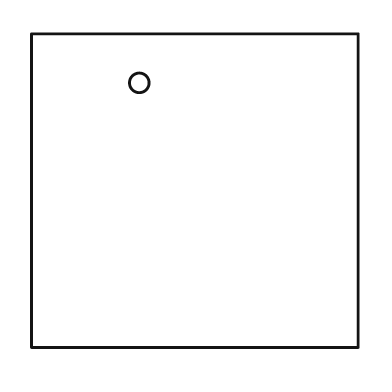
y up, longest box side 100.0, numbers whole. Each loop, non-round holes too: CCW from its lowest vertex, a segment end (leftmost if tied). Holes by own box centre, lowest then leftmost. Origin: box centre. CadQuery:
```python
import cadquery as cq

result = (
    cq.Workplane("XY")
    .moveTo(-50.0, -48.0)
    .lineTo(50.0, -48.0)
    .lineTo(50.0, 48.0)
    .lineTo(-50.0, 48.0)
    .close()
    .moveTo(-17.0, 33.0)
    .circle(3.0)
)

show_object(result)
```